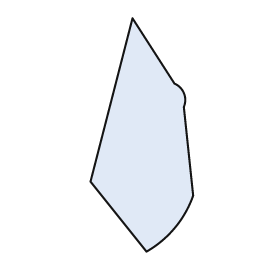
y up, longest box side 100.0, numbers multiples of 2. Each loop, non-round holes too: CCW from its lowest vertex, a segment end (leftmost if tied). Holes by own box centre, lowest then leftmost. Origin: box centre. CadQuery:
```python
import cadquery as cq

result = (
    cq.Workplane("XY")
    .moveTo(2.0, -50.0)
    .threePointArc((14.0, -40.0), (22.0, -26.0))
    .lineTo(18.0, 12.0)
    .threePointArc((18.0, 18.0), (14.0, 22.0))
    .lineTo(-4.0, 50.0)
    .lineTo(-22.0, -20.0)
    .close()
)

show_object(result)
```